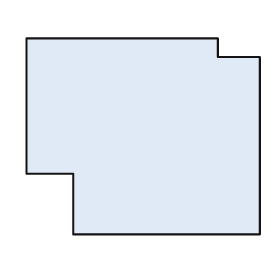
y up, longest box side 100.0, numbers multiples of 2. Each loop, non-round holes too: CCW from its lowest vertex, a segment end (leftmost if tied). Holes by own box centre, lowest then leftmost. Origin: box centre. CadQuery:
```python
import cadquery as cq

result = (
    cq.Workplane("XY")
    .moveTo(-30.0, -42.0)
    .lineTo(50.0, -42.0)
    .lineTo(50.0, 34.0)
    .lineTo(32.0, 34.0)
    .lineTo(32.0, 42.0)
    .lineTo(-50.0, 42.0)
    .lineTo(-50.0, -16.0)
    .lineTo(-30.0, -16.0)
    .close()
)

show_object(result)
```